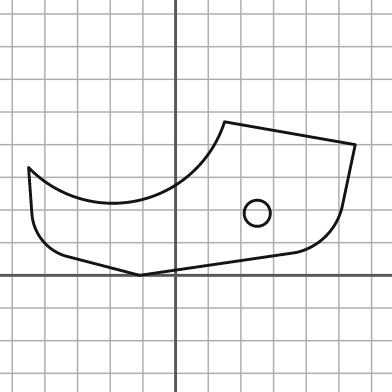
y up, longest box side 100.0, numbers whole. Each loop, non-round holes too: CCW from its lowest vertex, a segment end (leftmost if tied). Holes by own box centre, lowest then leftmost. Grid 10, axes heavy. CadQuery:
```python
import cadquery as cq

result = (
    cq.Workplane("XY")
    .moveTo(-11.0, 0.0)
    .lineTo(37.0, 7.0)
    .threePointArc((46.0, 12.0), (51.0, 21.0))
    .lineTo(55.0, 40.0)
    .lineTo(15.0, 47.0)
    .threePointArc((-11.0, 23.0), (-45.0, 33.0))
    .lineTo(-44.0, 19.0)
    .threePointArc((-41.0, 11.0), (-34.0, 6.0))
    .close()
    .moveTo(25.0, 19.0)
    .circle(4.0)
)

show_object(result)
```